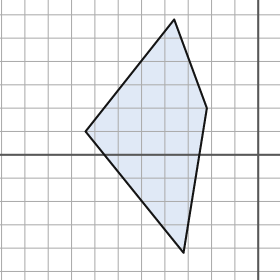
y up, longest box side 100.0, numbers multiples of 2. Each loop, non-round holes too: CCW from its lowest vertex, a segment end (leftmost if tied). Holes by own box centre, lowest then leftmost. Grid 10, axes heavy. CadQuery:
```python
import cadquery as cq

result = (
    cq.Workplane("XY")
    .moveTo(-32.0, -42.0)
    .lineTo(-22.0, 20.0)
    .lineTo(-36.0, 58.0)
    .lineTo(-74.0, 10.0)
    .close()
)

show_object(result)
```